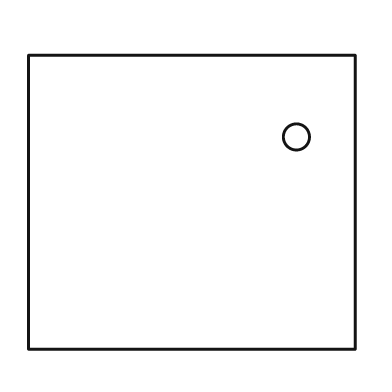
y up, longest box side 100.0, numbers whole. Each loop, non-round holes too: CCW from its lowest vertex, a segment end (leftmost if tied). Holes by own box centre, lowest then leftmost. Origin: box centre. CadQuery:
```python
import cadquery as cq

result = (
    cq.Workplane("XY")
    .moveTo(-50.0, -45.0)
    .lineTo(50.0, -45.0)
    .lineTo(50.0, 45.0)
    .lineTo(-50.0, 45.0)
    .close()
    .moveTo(32.0, 20.0)
    .circle(4.0)
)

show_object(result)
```